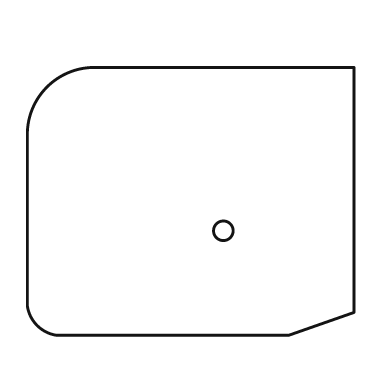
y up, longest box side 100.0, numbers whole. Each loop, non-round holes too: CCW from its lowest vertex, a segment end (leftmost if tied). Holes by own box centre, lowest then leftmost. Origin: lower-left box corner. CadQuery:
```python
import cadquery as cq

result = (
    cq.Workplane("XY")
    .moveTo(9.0, 0.0)
    .lineTo(80.0, 0.0)
    .lineTo(100.0, 7.0)
    .lineTo(100.0, 82.0)
    .lineTo(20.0, 82.0)
    .threePointArc((6.0, 76.0), (0.0, 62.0))
    .lineTo(0.0, 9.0)
    .threePointArc((3.0, 3.0), (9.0, 0.0))
    .close()
    .moveTo(60.0, 32.0)
    .circle(3.0)
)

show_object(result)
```